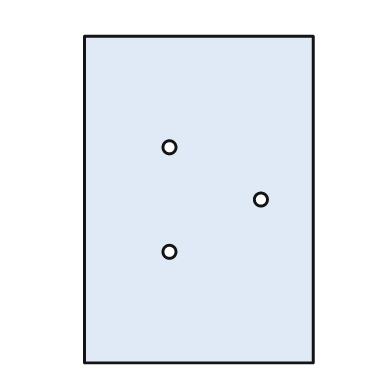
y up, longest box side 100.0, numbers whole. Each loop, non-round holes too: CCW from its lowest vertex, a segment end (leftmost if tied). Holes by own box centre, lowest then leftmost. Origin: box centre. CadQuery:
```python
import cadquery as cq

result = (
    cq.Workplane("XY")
    .moveTo(-35.0, -50.0)
    .lineTo(35.0, -50.0)
    .lineTo(35.0, 50.0)
    .lineTo(-35.0, 50.0)
    .close()
    .moveTo(-9.0, -16.0)
    .circle(2.0)
    .moveTo(19.0, 0.0)
    .circle(2.0)
    .moveTo(-9.0, 16.0)
    .circle(2.0)
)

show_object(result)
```